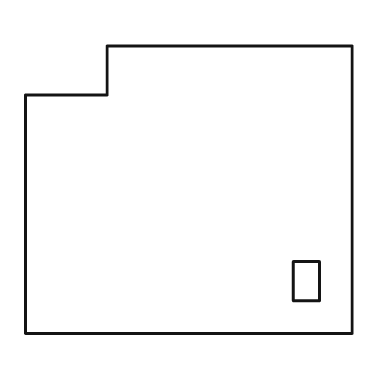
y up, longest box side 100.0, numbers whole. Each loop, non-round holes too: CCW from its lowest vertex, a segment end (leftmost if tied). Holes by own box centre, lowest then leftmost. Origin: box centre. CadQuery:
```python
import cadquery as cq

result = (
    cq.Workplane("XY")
    .moveTo(-50.0, -44.0)
    .lineTo(50.0, -44.0)
    .lineTo(50.0, 44.0)
    .lineTo(-25.0, 44.0)
    .lineTo(-25.0, 29.0)
    .lineTo(-50.0, 29.0)
    .close()
    .moveTo(32.0, -34.0)
    .lineTo(40.0, -34.0)
    .lineTo(40.0, -22.0)
    .lineTo(32.0, -22.0)
    .close()
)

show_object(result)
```